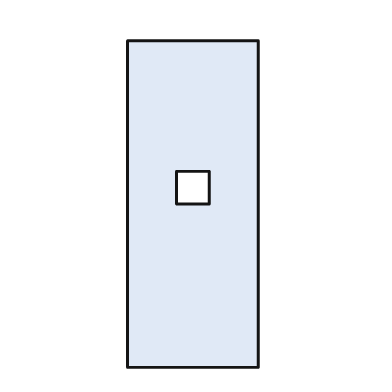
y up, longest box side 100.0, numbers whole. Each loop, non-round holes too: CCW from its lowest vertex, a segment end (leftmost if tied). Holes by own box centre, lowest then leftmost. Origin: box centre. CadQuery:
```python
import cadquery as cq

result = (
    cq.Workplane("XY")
    .moveTo(-20.0, -50.0)
    .lineTo(20.0, -50.0)
    .lineTo(20.0, 50.0)
    .lineTo(-20.0, 50.0)
    .close()
    .moveTo(-5.0, 0.0)
    .lineTo(5.0, 0.0)
    .lineTo(5.0, 10.0)
    .lineTo(-5.0, 10.0)
    .close()
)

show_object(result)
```